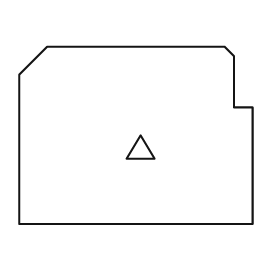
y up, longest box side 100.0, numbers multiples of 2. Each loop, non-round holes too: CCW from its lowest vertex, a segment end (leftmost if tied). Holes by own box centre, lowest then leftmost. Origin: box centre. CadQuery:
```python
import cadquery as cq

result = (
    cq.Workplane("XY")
    .moveTo(-50.0, -38.0)
    .lineTo(50.0, -38.0)
    .lineTo(50.0, 12.0)
    .lineTo(42.0, 12.0)
    .lineTo(42.0, 34.0)
    .lineTo(38.0, 38.0)
    .lineTo(-38.0, 38.0)
    .lineTo(-50.0, 26.0)
    .close()
    .moveTo(-4.0, -10.0)
    .lineTo(8.0, -10.0)
    .lineTo(2.0, 0.0)
    .close()
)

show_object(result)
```